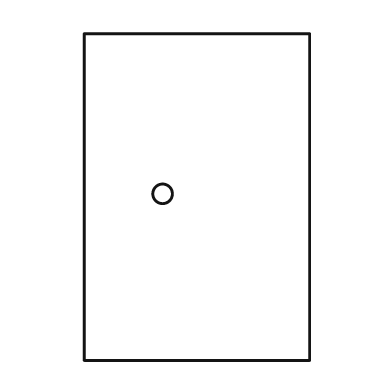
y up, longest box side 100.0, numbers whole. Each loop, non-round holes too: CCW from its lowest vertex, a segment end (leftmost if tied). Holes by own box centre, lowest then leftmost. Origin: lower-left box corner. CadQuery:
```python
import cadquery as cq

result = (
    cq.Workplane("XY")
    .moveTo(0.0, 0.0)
    .lineTo(69.0, 0.0)
    .lineTo(69.0, 100.0)
    .lineTo(0.0, 100.0)
    .close()
    .moveTo(24.0, 51.0)
    .circle(3.0)
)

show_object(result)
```